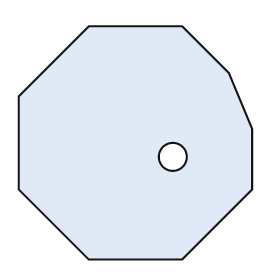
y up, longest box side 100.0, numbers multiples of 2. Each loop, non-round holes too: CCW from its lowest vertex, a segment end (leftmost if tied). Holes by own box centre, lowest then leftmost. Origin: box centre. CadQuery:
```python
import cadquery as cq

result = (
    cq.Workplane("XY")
    .moveTo(-20.0, -50.0)
    .lineTo(20.0, -50.0)
    .lineTo(50.0, -20.0)
    .lineTo(50.0, 6.0)
    .lineTo(40.0, 30.0)
    .lineTo(20.0, 50.0)
    .lineTo(-20.0, 50.0)
    .lineTo(-50.0, 20.0)
    .lineTo(-50.0, -20.0)
    .close()
    .moveTo(16.0, -6.0)
    .circle(6.0)
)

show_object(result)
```